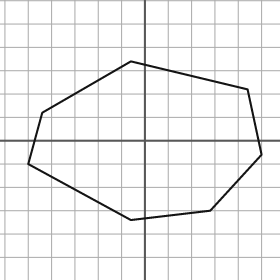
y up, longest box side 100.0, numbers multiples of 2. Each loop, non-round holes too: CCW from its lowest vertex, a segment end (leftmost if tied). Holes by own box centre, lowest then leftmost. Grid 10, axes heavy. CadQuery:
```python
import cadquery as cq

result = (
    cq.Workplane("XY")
    .moveTo(-6.0, -34.0)
    .lineTo(28.0, -30.0)
    .lineTo(50.0, -6.0)
    .lineTo(44.0, 22.0)
    .lineTo(-6.0, 34.0)
    .lineTo(-44.0, 12.0)
    .lineTo(-50.0, -10.0)
    .close()
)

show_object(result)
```